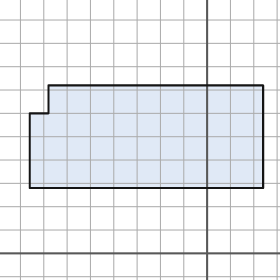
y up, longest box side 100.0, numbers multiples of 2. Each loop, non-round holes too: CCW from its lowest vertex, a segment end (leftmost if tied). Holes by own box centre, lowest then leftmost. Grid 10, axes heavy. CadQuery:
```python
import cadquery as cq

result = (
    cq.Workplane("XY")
    .moveTo(-76.0, 28.0)
    .lineTo(24.0, 28.0)
    .lineTo(24.0, 72.0)
    .lineTo(-68.0, 72.0)
    .lineTo(-68.0, 60.0)
    .lineTo(-76.0, 60.0)
    .close()
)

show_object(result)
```